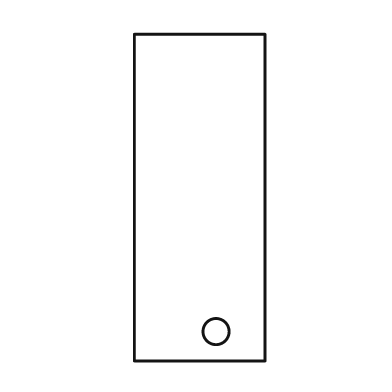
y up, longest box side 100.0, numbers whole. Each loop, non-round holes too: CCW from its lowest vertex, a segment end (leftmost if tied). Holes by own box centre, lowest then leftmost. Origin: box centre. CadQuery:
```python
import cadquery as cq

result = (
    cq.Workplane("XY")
    .moveTo(-20.0, -50.0)
    .lineTo(20.0, -50.0)
    .lineTo(20.0, 50.0)
    .lineTo(-20.0, 50.0)
    .close()
    .moveTo(5.0, -41.0)
    .circle(4.0)
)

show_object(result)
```